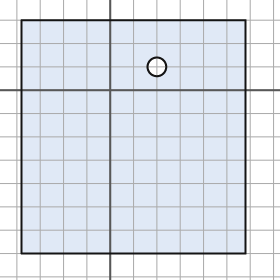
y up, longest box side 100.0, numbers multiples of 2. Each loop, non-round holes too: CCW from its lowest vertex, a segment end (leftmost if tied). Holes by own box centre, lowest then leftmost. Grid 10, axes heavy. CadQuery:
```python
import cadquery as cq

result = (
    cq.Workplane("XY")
    .moveTo(-38.0, -70.0)
    .lineTo(58.0, -70.0)
    .lineTo(58.0, 30.0)
    .lineTo(-38.0, 30.0)
    .close()
    .moveTo(20.0, 10.0)
    .circle(4.0)
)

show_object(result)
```